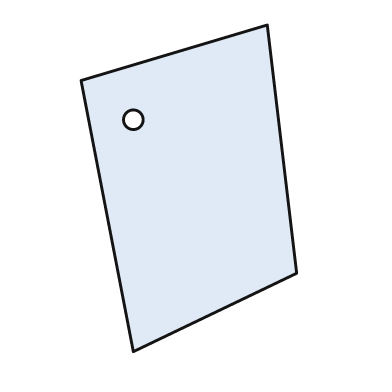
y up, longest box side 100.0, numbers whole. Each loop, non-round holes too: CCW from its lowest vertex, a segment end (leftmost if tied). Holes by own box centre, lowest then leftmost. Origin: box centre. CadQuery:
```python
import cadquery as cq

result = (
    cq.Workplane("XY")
    .moveTo(-17.0, -50.0)
    .lineTo(33.0, -26.0)
    .lineTo(24.0, 50.0)
    .lineTo(-33.0, 33.0)
    .close()
    .moveTo(-17.0, 21.0)
    .circle(3.0)
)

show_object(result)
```